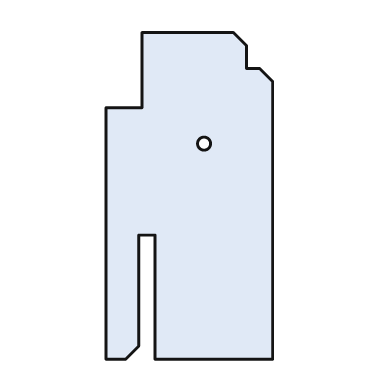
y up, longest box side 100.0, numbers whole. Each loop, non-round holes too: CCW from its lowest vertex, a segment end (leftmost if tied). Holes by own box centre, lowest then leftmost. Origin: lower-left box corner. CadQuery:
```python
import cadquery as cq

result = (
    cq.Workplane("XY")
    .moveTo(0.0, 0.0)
    .lineTo(6.0, 0.0)
    .lineTo(10.0, 4.0)
    .lineTo(10.0, 38.0)
    .lineTo(15.0, 38.0)
    .lineTo(15.0, 0.0)
    .lineTo(51.0, 0.0)
    .lineTo(51.0, 85.0)
    .lineTo(47.0, 89.0)
    .lineTo(43.0, 89.0)
    .lineTo(43.0, 96.0)
    .lineTo(39.0, 100.0)
    .lineTo(11.0, 100.0)
    .lineTo(11.0, 77.0)
    .lineTo(0.0, 77.0)
    .close()
    .moveTo(30.0, 66.0)
    .circle(2.0)
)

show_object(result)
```